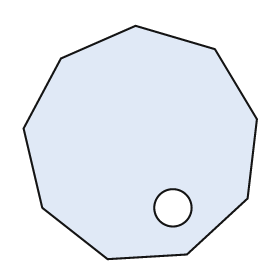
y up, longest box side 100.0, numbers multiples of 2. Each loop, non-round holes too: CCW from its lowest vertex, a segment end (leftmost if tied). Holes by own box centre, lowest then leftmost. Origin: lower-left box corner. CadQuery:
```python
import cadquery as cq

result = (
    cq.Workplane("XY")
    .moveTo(36.0, 0.0)
    .lineTo(70.0, 2.0)
    .lineTo(96.0, 26.0)
    .lineTo(100.0, 60.0)
    .lineTo(82.0, 90.0)
    .lineTo(48.0, 100.0)
    .lineTo(16.0, 86.0)
    .lineTo(0.0, 56.0)
    .lineTo(8.0, 22.0)
    .close()
    .moveTo(64.0, 22.0)
    .circle(8.0)
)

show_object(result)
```